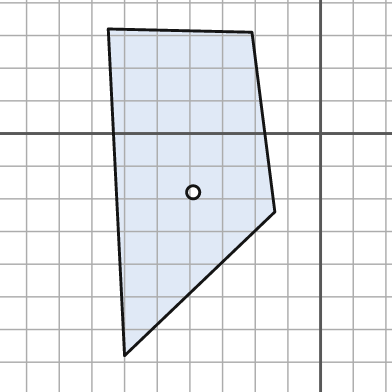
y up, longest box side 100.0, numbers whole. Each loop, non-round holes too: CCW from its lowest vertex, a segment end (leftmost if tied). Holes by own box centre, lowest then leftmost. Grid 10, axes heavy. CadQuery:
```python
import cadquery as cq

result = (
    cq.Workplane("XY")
    .moveTo(-60.0, -68.0)
    .lineTo(-14.0, -24.0)
    .lineTo(-21.0, 31.0)
    .lineTo(-65.0, 32.0)
    .close()
    .moveTo(-39.0, -18.0)
    .circle(2.0)
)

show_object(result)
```